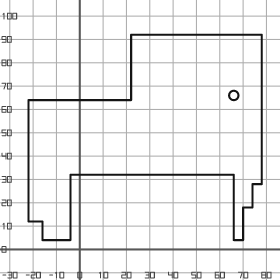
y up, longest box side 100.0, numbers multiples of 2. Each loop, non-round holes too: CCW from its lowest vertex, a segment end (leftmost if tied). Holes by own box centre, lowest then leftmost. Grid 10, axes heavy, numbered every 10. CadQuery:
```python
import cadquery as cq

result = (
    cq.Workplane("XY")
    .moveTo(-16.0, 4.0)
    .lineTo(-4.0, 4.0)
    .lineTo(-4.0, 32.0)
    .lineTo(66.0, 32.0)
    .lineTo(66.0, 4.0)
    .lineTo(70.0, 4.0)
    .lineTo(70.0, 18.0)
    .lineTo(74.0, 18.0)
    .lineTo(74.0, 28.0)
    .lineTo(78.0, 28.0)
    .lineTo(78.0, 92.0)
    .lineTo(22.0, 92.0)
    .lineTo(22.0, 64.0)
    .lineTo(-22.0, 64.0)
    .lineTo(-22.0, 12.0)
    .lineTo(-16.0, 12.0)
    .close()
    .moveTo(66.0, 66.0)
    .circle(2.0)
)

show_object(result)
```